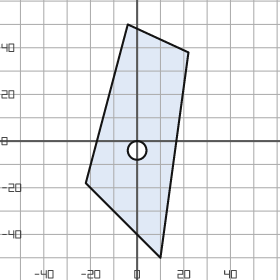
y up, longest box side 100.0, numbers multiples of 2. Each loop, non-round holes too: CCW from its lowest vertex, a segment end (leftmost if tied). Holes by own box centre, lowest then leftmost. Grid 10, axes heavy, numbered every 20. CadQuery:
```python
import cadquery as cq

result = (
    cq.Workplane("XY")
    .moveTo(10.0, -50.0)
    .lineTo(22.0, 38.0)
    .lineTo(-4.0, 50.0)
    .lineTo(-22.0, -18.0)
    .close()
    .moveTo(0.0, -4.0)
    .circle(4.0)
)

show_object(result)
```